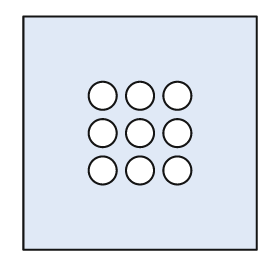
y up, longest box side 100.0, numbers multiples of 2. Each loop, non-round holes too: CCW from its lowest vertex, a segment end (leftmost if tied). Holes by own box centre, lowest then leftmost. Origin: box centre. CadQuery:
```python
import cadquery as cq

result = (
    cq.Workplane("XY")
    .moveTo(-50.0, -50.0)
    .lineTo(50.0, -50.0)
    .lineTo(50.0, 50.0)
    .lineTo(-50.0, 50.0)
    .close()
    .moveTo(-16.0, -16.0)
    .circle(6.0)
    .moveTo(0.0, -16.0)
    .circle(6.0)
    .moveTo(16.0, -16.0)
    .circle(6.0)
    .moveTo(-16.0, 0.0)
    .circle(6.0)
    .moveTo(0.0, 0.0)
    .circle(6.0)
    .moveTo(16.0, 0.0)
    .circle(6.0)
    .moveTo(-16.0, 16.0)
    .circle(6.0)
    .moveTo(0.0, 16.0)
    .circle(6.0)
    .moveTo(16.0, 16.0)
    .circle(6.0)
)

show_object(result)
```